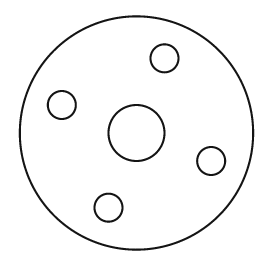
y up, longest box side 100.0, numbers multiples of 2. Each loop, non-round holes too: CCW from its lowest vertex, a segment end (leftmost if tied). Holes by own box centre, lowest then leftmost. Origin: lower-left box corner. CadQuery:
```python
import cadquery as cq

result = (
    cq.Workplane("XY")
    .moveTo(50.0, 50.0)
    .circle(50.0)
    .moveTo(38.0, 18.0)
    .circle(6.0)
    .moveTo(82.0, 38.0)
    .circle(6.0)
    .moveTo(50.0, 50.0)
    .circle(12.0)
    .moveTo(18.0, 62.0)
    .circle(6.0)
    .moveTo(62.0, 82.0)
    .circle(6.0)
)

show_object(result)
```